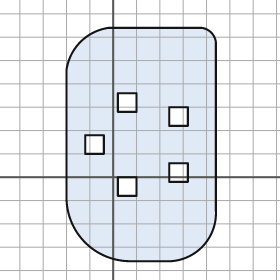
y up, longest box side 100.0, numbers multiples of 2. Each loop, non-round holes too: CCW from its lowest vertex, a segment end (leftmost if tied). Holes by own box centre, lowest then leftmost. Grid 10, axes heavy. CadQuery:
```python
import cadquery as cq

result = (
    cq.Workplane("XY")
    .moveTo(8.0, -36.0)
    .lineTo(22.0, -36.0)
    .threePointArc((38.0, -30.0), (44.0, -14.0))
    .lineTo(44.0, 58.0)
    .threePointArc((42.0, 62.0), (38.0, 64.0))
    .lineTo(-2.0, 64.0)
    .threePointArc((-14.0, 58.0), (-20.0, 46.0))
    .lineTo(-20.0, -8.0)
    .threePointArc((-12.0, -28.0), (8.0, -36.0))
    .close()
    .moveTo(2.0, -8.0)
    .lineTo(10.0, -8.0)
    .lineTo(10.0, 0.0)
    .lineTo(2.0, 0.0)
    .close()
    .moveTo(24.0, -2.0)
    .lineTo(32.0, -2.0)
    .lineTo(32.0, 6.0)
    .lineTo(24.0, 6.0)
    .close()
    .moveTo(-12.0, 10.0)
    .lineTo(-4.0, 10.0)
    .lineTo(-4.0, 18.0)
    .lineTo(-12.0, 18.0)
    .close()
    .moveTo(24.0, 22.0)
    .lineTo(32.0, 22.0)
    .lineTo(32.0, 30.0)
    .lineTo(24.0, 30.0)
    .close()
    .moveTo(2.0, 28.0)
    .lineTo(10.0, 28.0)
    .lineTo(10.0, 36.0)
    .lineTo(2.0, 36.0)
    .close()
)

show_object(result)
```